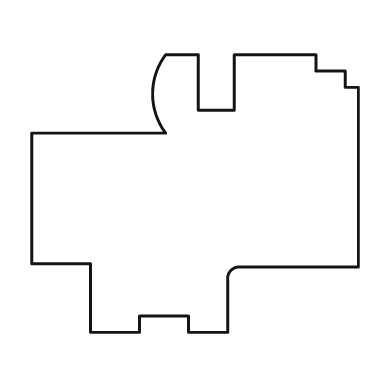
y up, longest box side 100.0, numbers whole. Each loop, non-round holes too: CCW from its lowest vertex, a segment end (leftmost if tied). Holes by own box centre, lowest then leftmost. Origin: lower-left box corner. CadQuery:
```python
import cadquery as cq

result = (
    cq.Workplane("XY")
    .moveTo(18.0, 0.0)
    .lineTo(33.0, 0.0)
    .lineTo(33.0, 5.0)
    .lineTo(48.0, 5.0)
    .lineTo(48.0, 0.0)
    .lineTo(60.0, 0.0)
    .lineTo(60.0, 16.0)
    .threePointArc((61.0, 19.0), (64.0, 20.0))
    .lineTo(100.0, 20.0)
    .lineTo(100.0, 75.0)
    .lineTo(96.0, 75.0)
    .lineTo(96.0, 80.0)
    .lineTo(87.0, 80.0)
    .lineTo(87.0, 85.0)
    .lineTo(62.0, 85.0)
    .lineTo(62.0, 68.0)
    .lineTo(51.0, 68.0)
    .lineTo(51.0, 85.0)
    .lineTo(41.0, 85.0)
    .threePointArc((37.0, 73.0), (41.0, 61.0))
    .lineTo(0.0, 61.0)
    .lineTo(0.0, 21.0)
    .lineTo(18.0, 21.0)
    .close()
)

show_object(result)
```